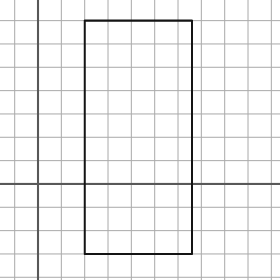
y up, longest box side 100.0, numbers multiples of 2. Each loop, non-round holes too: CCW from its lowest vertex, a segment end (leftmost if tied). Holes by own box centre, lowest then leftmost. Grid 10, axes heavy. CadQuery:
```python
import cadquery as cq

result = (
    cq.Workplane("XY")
    .moveTo(20.0, -30.0)
    .lineTo(66.0, -30.0)
    .lineTo(66.0, 70.0)
    .lineTo(20.0, 70.0)
    .close()
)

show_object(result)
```